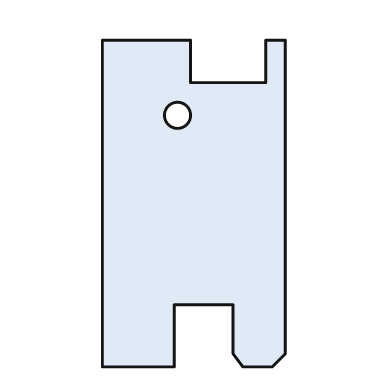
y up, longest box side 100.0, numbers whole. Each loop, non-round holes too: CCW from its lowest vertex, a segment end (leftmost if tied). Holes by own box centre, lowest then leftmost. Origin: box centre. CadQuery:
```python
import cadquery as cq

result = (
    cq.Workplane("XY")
    .moveTo(-28.0, -50.0)
    .lineTo(-6.0, -50.0)
    .lineTo(-6.0, -31.0)
    .lineTo(12.0, -31.0)
    .lineTo(12.0, -46.0)
    .lineTo(15.0, -50.0)
    .lineTo(24.0, -50.0)
    .lineTo(28.0, -46.0)
    .lineTo(28.0, 50.0)
    .lineTo(22.0, 50.0)
    .lineTo(22.0, 37.0)
    .lineTo(-1.0, 37.0)
    .lineTo(-1.0, 50.0)
    .lineTo(-28.0, 50.0)
    .close()
    .moveTo(-5.0, 27.0)
    .circle(4.0)
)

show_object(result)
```